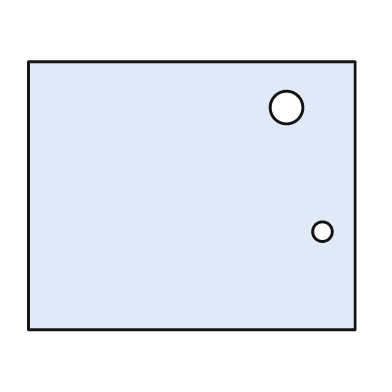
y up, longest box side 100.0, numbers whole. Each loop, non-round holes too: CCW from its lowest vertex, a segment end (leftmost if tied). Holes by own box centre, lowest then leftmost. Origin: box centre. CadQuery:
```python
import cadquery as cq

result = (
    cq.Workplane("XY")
    .moveTo(-50.0, -41.0)
    .lineTo(50.0, -41.0)
    .lineTo(50.0, 41.0)
    .lineTo(-50.0, 41.0)
    .close()
    .moveTo(40.0, -11.0)
    .circle(3.0)
    .moveTo(29.0, 27.0)
    .circle(5.0)
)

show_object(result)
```